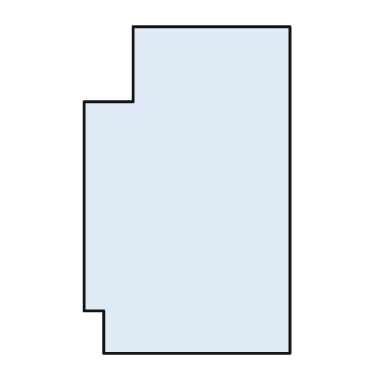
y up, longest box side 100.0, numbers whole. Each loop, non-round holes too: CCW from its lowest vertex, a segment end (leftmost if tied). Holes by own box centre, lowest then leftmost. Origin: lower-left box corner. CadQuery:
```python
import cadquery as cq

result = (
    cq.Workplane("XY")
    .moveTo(6.0, 0.0)
    .lineTo(63.0, 0.0)
    .lineTo(63.0, 100.0)
    .lineTo(15.0, 100.0)
    .lineTo(15.0, 77.0)
    .lineTo(0.0, 77.0)
    .lineTo(0.0, 13.0)
    .lineTo(6.0, 13.0)
    .close()
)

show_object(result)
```